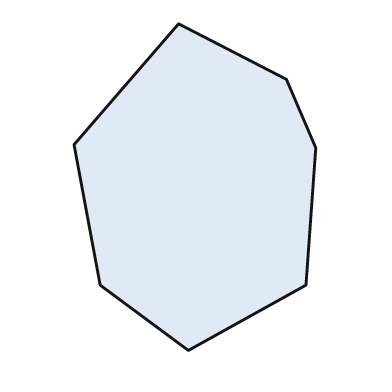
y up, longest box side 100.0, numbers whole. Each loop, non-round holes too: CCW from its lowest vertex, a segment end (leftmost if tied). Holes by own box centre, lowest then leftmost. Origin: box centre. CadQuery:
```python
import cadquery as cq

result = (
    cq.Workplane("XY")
    .moveTo(-2.0, -50.0)
    .lineTo(34.0, -30.0)
    .lineTo(37.0, 12.0)
    .lineTo(28.0, 33.0)
    .lineTo(-5.0, 50.0)
    .lineTo(-37.0, 13.0)
    .lineTo(-29.0, -30.0)
    .close()
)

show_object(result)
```